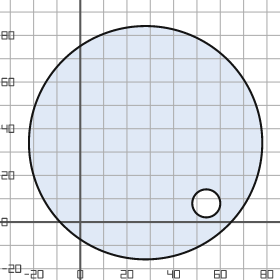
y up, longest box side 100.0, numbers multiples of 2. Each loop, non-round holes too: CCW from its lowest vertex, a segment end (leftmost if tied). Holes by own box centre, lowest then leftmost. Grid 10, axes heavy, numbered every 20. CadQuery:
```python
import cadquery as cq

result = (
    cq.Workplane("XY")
    .moveTo(28.0, 34.0)
    .circle(50.0)
    .moveTo(54.0, 8.0)
    .circle(6.0)
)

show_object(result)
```